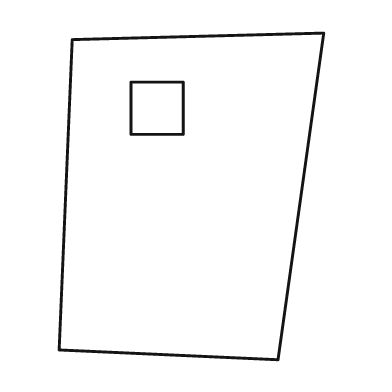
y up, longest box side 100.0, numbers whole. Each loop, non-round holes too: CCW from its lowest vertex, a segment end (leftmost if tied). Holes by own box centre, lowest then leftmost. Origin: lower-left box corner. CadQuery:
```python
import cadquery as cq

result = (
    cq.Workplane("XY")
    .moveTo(67.0, 0.0)
    .lineTo(81.0, 100.0)
    .lineTo(4.0, 98.0)
    .lineTo(0.0, 3.0)
    .close()
    .moveTo(22.0, 69.0)
    .lineTo(38.0, 69.0)
    .lineTo(38.0, 85.0)
    .lineTo(22.0, 85.0)
    .close()
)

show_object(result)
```